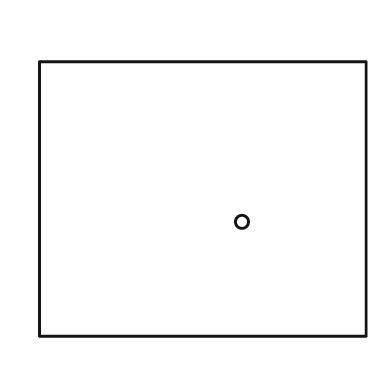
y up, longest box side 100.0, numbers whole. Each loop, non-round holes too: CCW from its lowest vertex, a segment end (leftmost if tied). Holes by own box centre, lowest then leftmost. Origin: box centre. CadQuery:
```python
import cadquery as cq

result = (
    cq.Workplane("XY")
    .moveTo(-50.0, -42.0)
    .lineTo(50.0, -42.0)
    .lineTo(50.0, 42.0)
    .lineTo(-50.0, 42.0)
    .close()
    .moveTo(12.0, -7.0)
    .circle(2.0)
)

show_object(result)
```